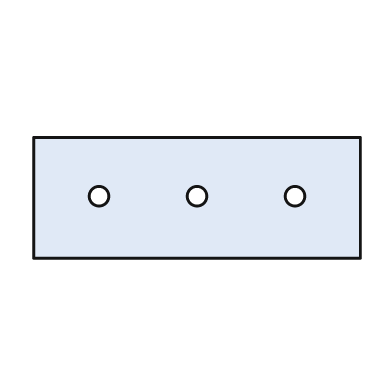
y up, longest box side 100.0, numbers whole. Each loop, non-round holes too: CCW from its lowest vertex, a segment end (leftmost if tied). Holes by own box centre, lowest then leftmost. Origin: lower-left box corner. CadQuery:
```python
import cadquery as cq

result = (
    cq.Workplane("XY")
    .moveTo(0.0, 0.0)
    .lineTo(100.0, 0.0)
    .lineTo(100.0, 37.0)
    .lineTo(0.0, 37.0)
    .close()
    .moveTo(20.0, 19.0)
    .circle(3.0)
    .moveTo(50.0, 19.0)
    .circle(3.0)
    .moveTo(80.0, 19.0)
    .circle(3.0)
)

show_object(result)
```